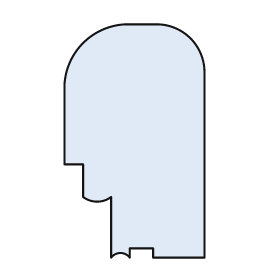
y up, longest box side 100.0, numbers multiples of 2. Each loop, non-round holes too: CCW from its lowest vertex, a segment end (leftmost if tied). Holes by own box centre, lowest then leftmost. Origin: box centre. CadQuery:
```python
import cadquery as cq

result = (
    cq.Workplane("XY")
    .moveTo(-10.0, -50.0)
    .threePointArc((-6.0, -48.0), (-2.0, -50.0))
    .lineTo(-2.0, -46.0)
    .lineTo(8.0, -46.0)
    .lineTo(8.0, -50.0)
    .lineTo(30.0, -50.0)
    .lineTo(30.0, 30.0)
    .threePointArc((24.0, 44.0), (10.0, 50.0))
    .lineTo(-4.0, 50.0)
    .threePointArc((-22.0, 42.0), (-30.0, 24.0))
    .lineTo(-30.0, -10.0)
    .lineTo(-22.0, -10.0)
    .lineTo(-22.0, -24.0)
    .threePointArc((-16.0, -26.0), (-10.0, -24.0))
    .close()
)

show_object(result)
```